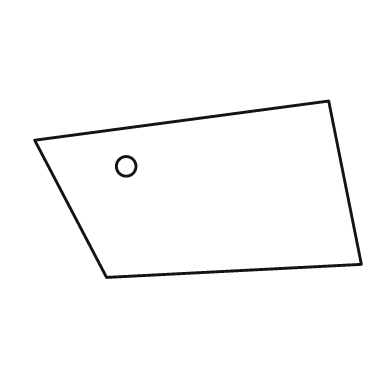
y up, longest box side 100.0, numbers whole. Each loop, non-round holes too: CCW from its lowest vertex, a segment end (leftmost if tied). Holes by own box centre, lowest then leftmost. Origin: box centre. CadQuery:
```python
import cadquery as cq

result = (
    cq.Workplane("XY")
    .moveTo(-28.0, -27.0)
    .lineTo(50.0, -23.0)
    .lineTo(40.0, 27.0)
    .lineTo(-50.0, 15.0)
    .close()
    .moveTo(-22.0, 7.0)
    .circle(3.0)
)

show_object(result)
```